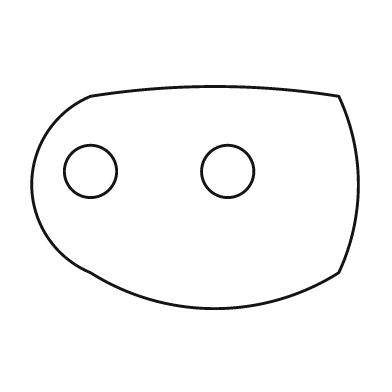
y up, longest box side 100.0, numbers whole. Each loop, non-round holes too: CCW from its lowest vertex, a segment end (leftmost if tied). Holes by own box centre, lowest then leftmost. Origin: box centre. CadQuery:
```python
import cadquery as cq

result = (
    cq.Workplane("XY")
    .moveTo(-32.0, -23.0)
    .threePointArc((6.0, -34.0), (44.0, -23.0))
    .threePointArc((50.0, 4.0), (44.0, 31.0))
    .threePointArc((6.0, 34.0), (-32.0, 31.0))
    .threePointArc((-50.0, 4.0), (-32.0, -23.0))
    .close()
    .moveTo(-32.0, 8.0)
    .circle(8.0)
    .moveTo(10.0, 8.0)
    .circle(8.0)
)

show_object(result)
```